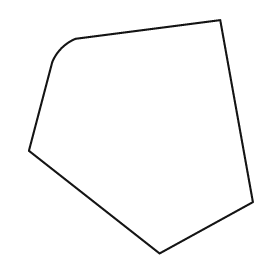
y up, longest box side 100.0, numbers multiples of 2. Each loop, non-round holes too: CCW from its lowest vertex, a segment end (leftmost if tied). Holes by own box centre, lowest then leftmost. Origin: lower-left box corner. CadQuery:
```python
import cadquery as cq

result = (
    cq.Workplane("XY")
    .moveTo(56.0, 0.0)
    .lineTo(96.0, 22.0)
    .lineTo(82.0, 100.0)
    .lineTo(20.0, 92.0)
    .threePointArc((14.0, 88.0), (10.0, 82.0))
    .lineTo(0.0, 44.0)
    .close()
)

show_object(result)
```